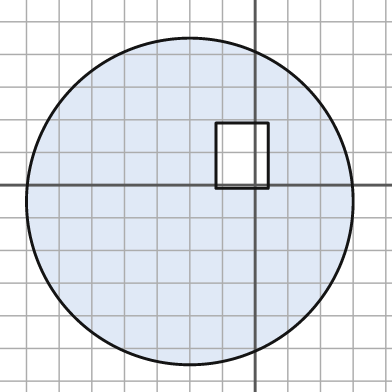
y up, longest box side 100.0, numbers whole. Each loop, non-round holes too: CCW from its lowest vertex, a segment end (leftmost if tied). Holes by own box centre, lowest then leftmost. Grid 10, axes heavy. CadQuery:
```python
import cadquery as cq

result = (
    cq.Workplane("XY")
    .moveTo(-20.0, -5.0)
    .circle(50.0)
    .moveTo(-12.0, -1.0)
    .lineTo(4.0, -1.0)
    .lineTo(4.0, 19.0)
    .lineTo(-12.0, 19.0)
    .close()
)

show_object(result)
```